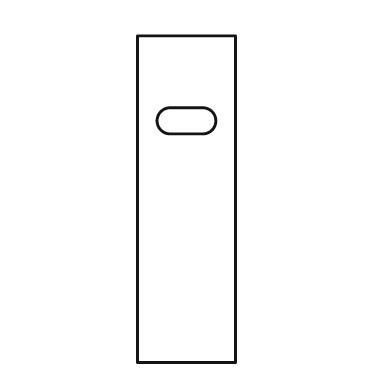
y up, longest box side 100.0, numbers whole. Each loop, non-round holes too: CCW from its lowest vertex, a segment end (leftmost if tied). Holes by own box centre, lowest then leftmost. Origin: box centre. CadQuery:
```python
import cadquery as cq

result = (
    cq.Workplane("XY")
    .moveTo(-15.0, -50.0)
    .lineTo(15.0, -50.0)
    .lineTo(15.0, 50.0)
    .lineTo(-15.0, 50.0)
    .close()
    .moveTo(-5.0, 20.0)
    .lineTo(5.0, 20.0)
    .threePointArc((9.0, 24.0), (5.0, 28.0))
    .lineTo(-5.0, 28.0)
    .threePointArc((-9.0, 24.0), (-5.0, 20.0))
    .close()
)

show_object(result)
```